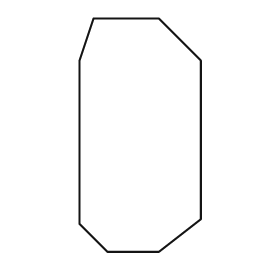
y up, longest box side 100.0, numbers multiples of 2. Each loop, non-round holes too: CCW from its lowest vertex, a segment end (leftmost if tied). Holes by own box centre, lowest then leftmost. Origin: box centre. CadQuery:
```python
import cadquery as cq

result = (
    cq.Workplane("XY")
    .moveTo(-14.0, -50.0)
    .lineTo(8.0, -50.0)
    .lineTo(26.0, -36.0)
    .lineTo(26.0, 32.0)
    .lineTo(8.0, 50.0)
    .lineTo(-20.0, 50.0)
    .lineTo(-26.0, 32.0)
    .lineTo(-26.0, -38.0)
    .close()
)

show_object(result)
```